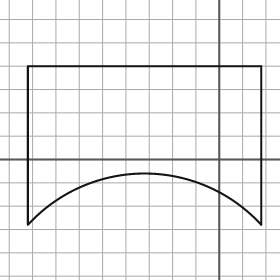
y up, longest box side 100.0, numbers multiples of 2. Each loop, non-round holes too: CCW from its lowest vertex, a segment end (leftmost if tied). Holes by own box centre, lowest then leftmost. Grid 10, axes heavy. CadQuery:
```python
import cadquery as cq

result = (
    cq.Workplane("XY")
    .moveTo(-82.0, -28.0)
    .threePointArc((-32.0, -6.0), (18.0, -28.0))
    .lineTo(18.0, 40.0)
    .lineTo(-82.0, 40.0)
    .close()
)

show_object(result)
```